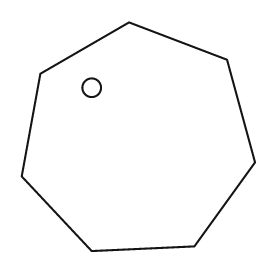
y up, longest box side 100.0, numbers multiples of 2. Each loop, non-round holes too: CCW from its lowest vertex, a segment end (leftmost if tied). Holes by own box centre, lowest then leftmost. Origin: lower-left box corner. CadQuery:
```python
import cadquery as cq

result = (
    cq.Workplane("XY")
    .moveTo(30.0, 0.0)
    .lineTo(74.0, 2.0)
    .lineTo(100.0, 38.0)
    .lineTo(88.0, 82.0)
    .lineTo(46.0, 98.0)
    .lineTo(8.0, 76.0)
    .lineTo(0.0, 32.0)
    .close()
    .moveTo(30.0, 70.0)
    .circle(4.0)
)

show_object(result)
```